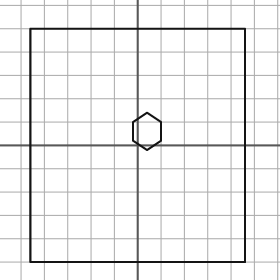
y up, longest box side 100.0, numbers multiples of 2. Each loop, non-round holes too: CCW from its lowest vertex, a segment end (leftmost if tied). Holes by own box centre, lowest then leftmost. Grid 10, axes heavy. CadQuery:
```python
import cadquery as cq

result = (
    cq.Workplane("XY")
    .moveTo(-46.0, -50.0)
    .lineTo(46.0, -50.0)
    .lineTo(46.0, 50.0)
    .lineTo(-46.0, 50.0)
    .close()
    .moveTo(4.0, -2.0)
    .lineTo(10.0, 2.0)
    .lineTo(10.0, 10.0)
    .lineTo(4.0, 14.0)
    .lineTo(-2.0, 10.0)
    .lineTo(-2.0, 2.0)
    .close()
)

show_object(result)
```